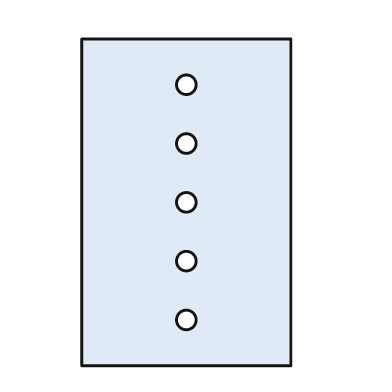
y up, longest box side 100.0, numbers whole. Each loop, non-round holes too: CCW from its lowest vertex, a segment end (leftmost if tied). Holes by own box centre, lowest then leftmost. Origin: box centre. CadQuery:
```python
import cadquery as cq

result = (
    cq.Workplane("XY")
    .moveTo(-32.0, -50.0)
    .lineTo(32.0, -50.0)
    .lineTo(32.0, 50.0)
    .lineTo(-32.0, 50.0)
    .close()
    .moveTo(0.0, -36.0)
    .circle(3.0)
    .moveTo(0.0, -18.0)
    .circle(3.0)
    .moveTo(0.0, 0.0)
    .circle(3.0)
    .moveTo(0.0, 18.0)
    .circle(3.0)
    .moveTo(0.0, 36.0)
    .circle(3.0)
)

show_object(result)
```